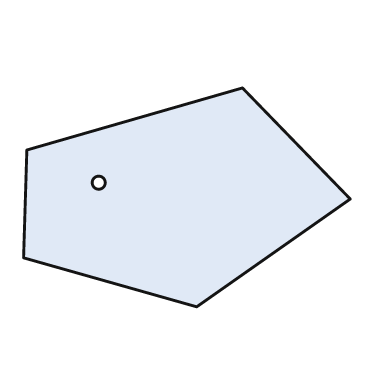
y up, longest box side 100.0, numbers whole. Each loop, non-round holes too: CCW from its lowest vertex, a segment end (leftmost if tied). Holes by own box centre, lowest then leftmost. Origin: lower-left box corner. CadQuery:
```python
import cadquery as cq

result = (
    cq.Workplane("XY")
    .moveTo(53.0, 0.0)
    .lineTo(100.0, 33.0)
    .lineTo(67.0, 67.0)
    .lineTo(1.0, 48.0)
    .lineTo(0.0, 15.0)
    .close()
    .moveTo(23.0, 38.0)
    .circle(2.0)
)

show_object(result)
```